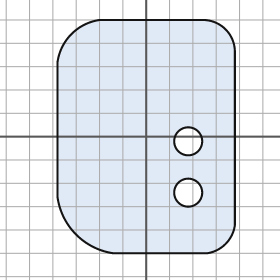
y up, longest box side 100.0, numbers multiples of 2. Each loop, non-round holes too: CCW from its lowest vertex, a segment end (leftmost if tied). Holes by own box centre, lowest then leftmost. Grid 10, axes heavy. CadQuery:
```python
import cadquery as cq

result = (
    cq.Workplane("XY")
    .moveTo(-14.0, -50.0)
    .lineTo(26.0, -50.0)
    .threePointArc((34.0, -46.0), (38.0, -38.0))
    .lineTo(38.0, 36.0)
    .threePointArc((34.0, 46.0), (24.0, 50.0))
    .lineTo(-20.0, 50.0)
    .threePointArc((-32.0, 44.0), (-38.0, 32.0))
    .lineTo(-38.0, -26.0)
    .threePointArc((-30.0, -42.0), (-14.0, -50.0))
    .close()
    .moveTo(18.0, -24.0)
    .circle(6.0)
    .moveTo(18.0, -2.0)
    .circle(6.0)
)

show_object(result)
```